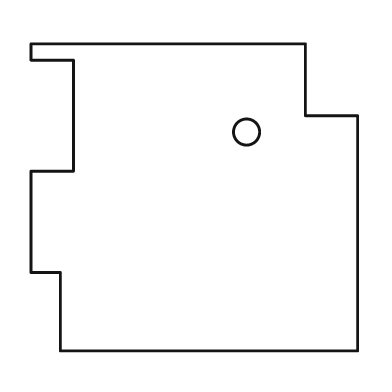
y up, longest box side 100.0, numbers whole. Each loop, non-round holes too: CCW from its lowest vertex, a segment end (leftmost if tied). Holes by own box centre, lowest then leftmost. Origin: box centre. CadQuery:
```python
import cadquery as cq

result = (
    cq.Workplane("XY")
    .moveTo(-41.0, -47.0)
    .lineTo(50.0, -47.0)
    .lineTo(50.0, 25.0)
    .lineTo(34.0, 25.0)
    .lineTo(34.0, 47.0)
    .lineTo(-50.0, 47.0)
    .lineTo(-50.0, 42.0)
    .lineTo(-37.0, 42.0)
    .lineTo(-37.0, 8.0)
    .lineTo(-50.0, 8.0)
    .lineTo(-50.0, -23.0)
    .lineTo(-41.0, -23.0)
    .close()
    .moveTo(16.0, 20.0)
    .circle(4.0)
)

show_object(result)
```